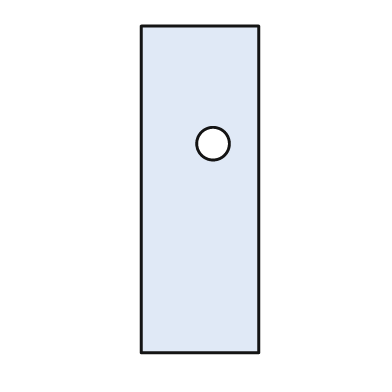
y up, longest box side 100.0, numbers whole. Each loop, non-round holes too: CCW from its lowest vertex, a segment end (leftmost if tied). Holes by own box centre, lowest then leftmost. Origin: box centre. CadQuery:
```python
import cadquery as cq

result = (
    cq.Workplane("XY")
    .moveTo(-18.0, -50.0)
    .lineTo(18.0, -50.0)
    .lineTo(18.0, 50.0)
    .lineTo(-18.0, 50.0)
    .close()
    .moveTo(4.0, 14.0)
    .circle(5.0)
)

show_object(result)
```